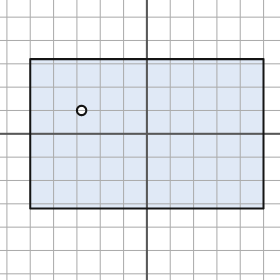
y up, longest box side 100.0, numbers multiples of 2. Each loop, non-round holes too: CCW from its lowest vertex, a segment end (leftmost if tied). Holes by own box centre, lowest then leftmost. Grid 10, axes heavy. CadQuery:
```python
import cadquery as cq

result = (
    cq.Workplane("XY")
    .moveTo(-50.0, -32.0)
    .lineTo(50.0, -32.0)
    .lineTo(50.0, 32.0)
    .lineTo(-50.0, 32.0)
    .close()
    .moveTo(-28.0, 10.0)
    .circle(2.0)
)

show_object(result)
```